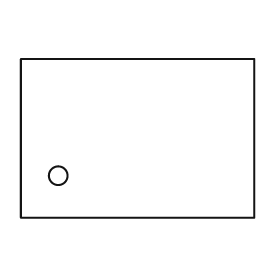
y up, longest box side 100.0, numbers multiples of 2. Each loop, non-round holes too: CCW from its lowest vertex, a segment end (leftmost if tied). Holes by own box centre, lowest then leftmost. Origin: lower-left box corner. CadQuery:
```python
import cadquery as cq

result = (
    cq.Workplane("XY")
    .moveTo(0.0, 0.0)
    .lineTo(100.0, 0.0)
    .lineTo(100.0, 68.0)
    .lineTo(0.0, 68.0)
    .close()
    .moveTo(16.0, 18.0)
    .circle(4.0)
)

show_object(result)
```